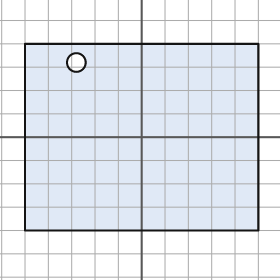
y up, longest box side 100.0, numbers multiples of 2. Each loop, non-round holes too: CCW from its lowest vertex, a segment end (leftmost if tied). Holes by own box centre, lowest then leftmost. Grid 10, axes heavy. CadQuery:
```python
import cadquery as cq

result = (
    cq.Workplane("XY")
    .moveTo(-50.0, -40.0)
    .lineTo(50.0, -40.0)
    .lineTo(50.0, 40.0)
    .lineTo(-50.0, 40.0)
    .close()
    .moveTo(-28.0, 32.0)
    .circle(4.0)
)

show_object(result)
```